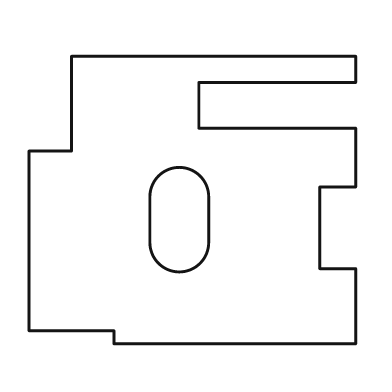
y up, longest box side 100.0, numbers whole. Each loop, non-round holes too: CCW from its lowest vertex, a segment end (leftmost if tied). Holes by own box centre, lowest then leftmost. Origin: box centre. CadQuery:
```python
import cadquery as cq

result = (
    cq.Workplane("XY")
    .moveTo(-24.0, -44.0)
    .lineTo(50.0, -44.0)
    .lineTo(50.0, -21.0)
    .lineTo(39.0, -21.0)
    .lineTo(39.0, 4.0)
    .lineTo(50.0, 4.0)
    .lineTo(50.0, 22.0)
    .lineTo(2.0, 22.0)
    .lineTo(2.0, 36.0)
    .lineTo(50.0, 36.0)
    .lineTo(50.0, 44.0)
    .lineTo(-37.0, 44.0)
    .lineTo(-37.0, 15.0)
    .lineTo(-50.0, 15.0)
    .lineTo(-50.0, -40.0)
    .lineTo(-24.0, -40.0)
    .close()
    .moveTo(-13.0, -13.0)
    .threePointArc((-4.0, -22.0), (5.0, -13.0))
    .lineTo(5.0, 1.0)
    .threePointArc((-4.0, 10.0), (-13.0, 1.0))
    .close()
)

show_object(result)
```